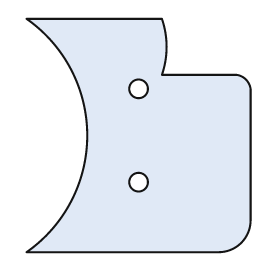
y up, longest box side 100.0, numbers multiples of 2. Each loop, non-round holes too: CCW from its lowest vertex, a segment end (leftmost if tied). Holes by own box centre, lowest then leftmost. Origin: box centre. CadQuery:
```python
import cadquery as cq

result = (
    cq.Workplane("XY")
    .moveTo(-48.0, -50.0)
    .lineTo(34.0, -50.0)
    .threePointArc((44.0, -46.0), (48.0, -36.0))
    .lineTo(48.0, 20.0)
    .threePointArc((46.0, 24.0), (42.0, 26.0))
    .lineTo(10.0, 26.0)
    .threePointArc((12.0, 38.0), (10.0, 50.0))
    .lineTo(-48.0, 50.0)
    .threePointArc((-22.0, 0.0), (-48.0, -50.0))
    .close()
    .moveTo(0.0, -20.0)
    .circle(4.0)
    .moveTo(0.0, 20.0)
    .circle(4.0)
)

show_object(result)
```